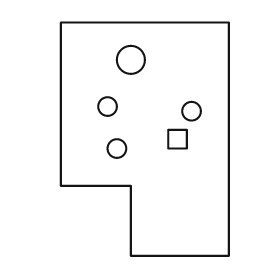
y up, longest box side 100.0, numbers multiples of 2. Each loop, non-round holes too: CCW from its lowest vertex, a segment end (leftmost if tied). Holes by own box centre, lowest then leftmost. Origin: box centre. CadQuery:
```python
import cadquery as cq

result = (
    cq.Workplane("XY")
    .moveTo(-6.0, -50.0)
    .lineTo(36.0, -50.0)
    .lineTo(36.0, 50.0)
    .lineTo(-36.0, 50.0)
    .lineTo(-36.0, -20.0)
    .lineTo(-6.0, -20.0)
    .close()
    .moveTo(-12.0, -4.0)
    .circle(4.0)
    .moveTo(10.0, -4.0)
    .lineTo(18.0, -4.0)
    .lineTo(18.0, 4.0)
    .lineTo(10.0, 4.0)
    .close()
    .moveTo(20.0, 12.0)
    .circle(4.0)
    .moveTo(-16.0, 14.0)
    .circle(4.0)
    .moveTo(-6.0, 34.0)
    .circle(6.0)
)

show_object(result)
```